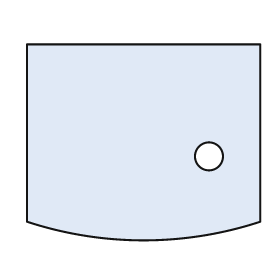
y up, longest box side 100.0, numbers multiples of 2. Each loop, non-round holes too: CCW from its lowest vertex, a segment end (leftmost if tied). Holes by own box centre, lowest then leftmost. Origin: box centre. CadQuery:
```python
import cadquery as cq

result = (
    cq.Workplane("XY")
    .moveTo(-50.0, -34.0)
    .threePointArc((0.0, -42.0), (50.0, -34.0))
    .lineTo(50.0, 42.0)
    .lineTo(-50.0, 42.0)
    .close()
    .moveTo(28.0, -6.0)
    .circle(6.0)
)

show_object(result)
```